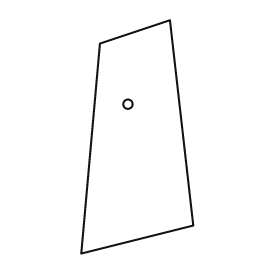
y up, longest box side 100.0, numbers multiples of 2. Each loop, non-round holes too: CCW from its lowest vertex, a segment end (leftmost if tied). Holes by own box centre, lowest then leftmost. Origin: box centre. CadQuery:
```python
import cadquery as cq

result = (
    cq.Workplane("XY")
    .moveTo(-24.0, -50.0)
    .lineTo(24.0, -38.0)
    .lineTo(14.0, 50.0)
    .lineTo(-16.0, 40.0)
    .close()
    .moveTo(-4.0, 14.0)
    .circle(2.0)
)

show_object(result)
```